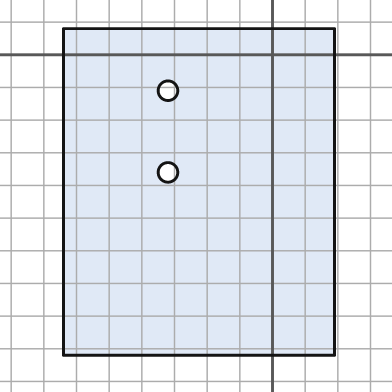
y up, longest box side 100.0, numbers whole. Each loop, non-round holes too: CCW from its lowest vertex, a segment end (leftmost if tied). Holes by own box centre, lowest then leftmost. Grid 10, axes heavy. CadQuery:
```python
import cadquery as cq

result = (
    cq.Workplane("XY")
    .moveTo(-64.0, -92.0)
    .lineTo(19.0, -92.0)
    .lineTo(19.0, 8.0)
    .lineTo(-64.0, 8.0)
    .close()
    .moveTo(-32.0, -36.0)
    .circle(3.0)
    .moveTo(-32.0, -11.0)
    .circle(3.0)
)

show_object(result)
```